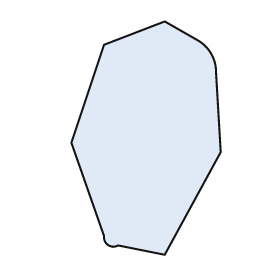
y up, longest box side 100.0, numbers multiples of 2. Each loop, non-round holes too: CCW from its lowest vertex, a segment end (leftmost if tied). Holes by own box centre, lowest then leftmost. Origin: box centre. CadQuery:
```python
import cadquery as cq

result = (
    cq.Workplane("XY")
    .moveTo(8.0, -50.0)
    .lineTo(32.0, -6.0)
    .lineTo(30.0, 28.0)
    .threePointArc((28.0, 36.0), (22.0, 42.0))
    .lineTo(8.0, 50.0)
    .lineTo(-18.0, 40.0)
    .lineTo(-32.0, -2.0)
    .lineTo(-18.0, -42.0)
    .threePointArc((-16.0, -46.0), (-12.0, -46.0))
    .close()
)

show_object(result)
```